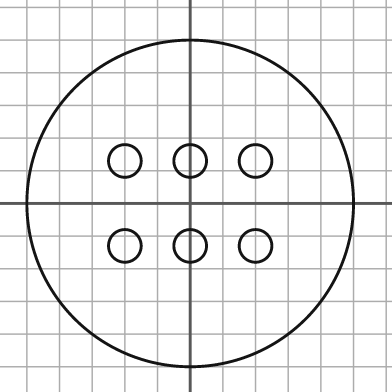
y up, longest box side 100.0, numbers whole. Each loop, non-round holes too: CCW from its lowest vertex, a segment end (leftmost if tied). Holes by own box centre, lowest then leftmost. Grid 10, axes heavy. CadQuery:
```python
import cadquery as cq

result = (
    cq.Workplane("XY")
    .moveTo(0.0, 0.0)
    .circle(50.0)
    .moveTo(-20.0, -13.0)
    .circle(5.0)
    .moveTo(0.0, -13.0)
    .circle(5.0)
    .moveTo(20.0, -13.0)
    .circle(5.0)
    .moveTo(-20.0, 13.0)
    .circle(5.0)
    .moveTo(0.0, 13.0)
    .circle(5.0)
    .moveTo(20.0, 13.0)
    .circle(5.0)
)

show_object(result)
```